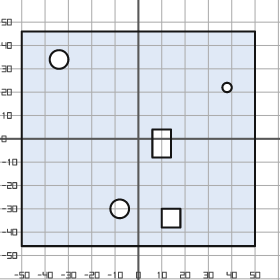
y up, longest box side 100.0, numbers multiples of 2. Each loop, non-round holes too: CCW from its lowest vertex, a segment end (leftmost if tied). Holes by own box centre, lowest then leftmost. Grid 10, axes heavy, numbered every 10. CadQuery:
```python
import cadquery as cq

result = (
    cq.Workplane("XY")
    .moveTo(-50.0, -46.0)
    .lineTo(50.0, -46.0)
    .lineTo(50.0, 46.0)
    .lineTo(-50.0, 46.0)
    .close()
    .moveTo(10.0, -38.0)
    .lineTo(18.0, -38.0)
    .lineTo(18.0, -30.0)
    .lineTo(10.0, -30.0)
    .close()
    .moveTo(-8.0, -30.0)
    .circle(4.0)
    .moveTo(6.0, -8.0)
    .lineTo(14.0, -8.0)
    .lineTo(14.0, 4.0)
    .lineTo(6.0, 4.0)
    .close()
    .moveTo(38.0, 22.0)
    .circle(2.0)
    .moveTo(-34.0, 34.0)
    .circle(4.0)
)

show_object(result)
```